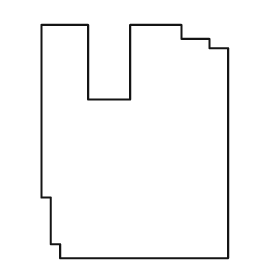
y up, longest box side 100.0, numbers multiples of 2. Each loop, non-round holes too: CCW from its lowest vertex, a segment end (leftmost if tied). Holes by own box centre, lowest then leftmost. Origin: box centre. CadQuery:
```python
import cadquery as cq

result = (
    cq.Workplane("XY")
    .moveTo(-32.0, -50.0)
    .lineTo(40.0, -50.0)
    .lineTo(40.0, 40.0)
    .lineTo(32.0, 40.0)
    .lineTo(32.0, 44.0)
    .lineTo(20.0, 44.0)
    .lineTo(20.0, 50.0)
    .lineTo(-2.0, 50.0)
    .lineTo(-2.0, 18.0)
    .lineTo(-20.0, 18.0)
    .lineTo(-20.0, 50.0)
    .lineTo(-40.0, 50.0)
    .lineTo(-40.0, -24.0)
    .lineTo(-36.0, -24.0)
    .lineTo(-36.0, -44.0)
    .lineTo(-32.0, -44.0)
    .close()
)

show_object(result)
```